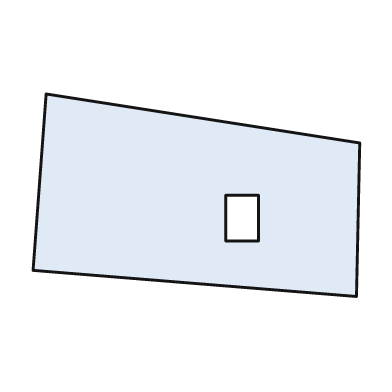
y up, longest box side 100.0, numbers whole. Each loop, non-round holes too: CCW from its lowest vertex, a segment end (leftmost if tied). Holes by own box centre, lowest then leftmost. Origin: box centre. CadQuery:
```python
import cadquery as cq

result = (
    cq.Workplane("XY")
    .moveTo(49.0, -31.0)
    .lineTo(50.0, 16.0)
    .lineTo(-46.0, 31.0)
    .lineTo(-50.0, -23.0)
    .close()
    .moveTo(9.0, -14.0)
    .lineTo(19.0, -14.0)
    .lineTo(19.0, 0.0)
    .lineTo(9.0, 0.0)
    .close()
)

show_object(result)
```